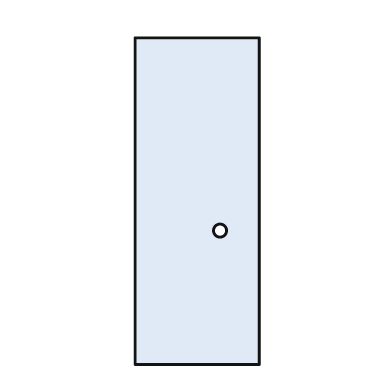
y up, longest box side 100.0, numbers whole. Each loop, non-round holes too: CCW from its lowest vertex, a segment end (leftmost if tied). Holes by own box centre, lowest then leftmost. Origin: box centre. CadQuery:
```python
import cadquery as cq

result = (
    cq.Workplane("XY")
    .moveTo(-19.0, -50.0)
    .lineTo(19.0, -50.0)
    .lineTo(19.0, 50.0)
    .lineTo(-19.0, 50.0)
    .close()
    .moveTo(7.0, -9.0)
    .circle(2.0)
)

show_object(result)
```